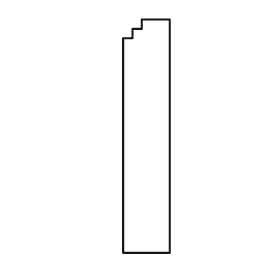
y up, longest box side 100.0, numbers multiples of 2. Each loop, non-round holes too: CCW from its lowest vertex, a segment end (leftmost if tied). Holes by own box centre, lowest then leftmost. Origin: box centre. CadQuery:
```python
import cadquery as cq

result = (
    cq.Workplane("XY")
    .moveTo(-10.0, -50.0)
    .lineTo(10.0, -50.0)
    .lineTo(10.0, 50.0)
    .lineTo(-2.0, 50.0)
    .lineTo(-2.0, 46.0)
    .lineTo(-6.0, 46.0)
    .lineTo(-6.0, 42.0)
    .lineTo(-10.0, 42.0)
    .close()
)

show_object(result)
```